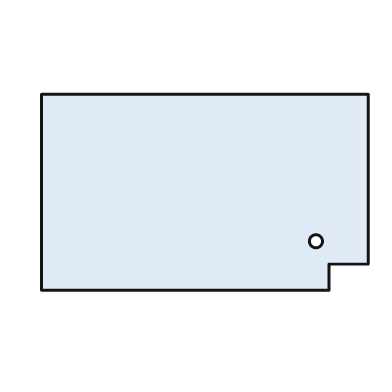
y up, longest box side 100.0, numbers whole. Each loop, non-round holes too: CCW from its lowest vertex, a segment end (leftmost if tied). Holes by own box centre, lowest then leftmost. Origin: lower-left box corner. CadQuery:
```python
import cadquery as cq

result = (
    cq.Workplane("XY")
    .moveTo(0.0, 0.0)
    .lineTo(88.0, 0.0)
    .lineTo(88.0, 8.0)
    .lineTo(100.0, 8.0)
    .lineTo(100.0, 60.0)
    .lineTo(0.0, 60.0)
    .close()
    .moveTo(84.0, 15.0)
    .circle(2.0)
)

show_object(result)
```